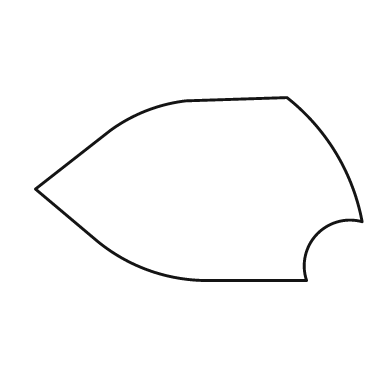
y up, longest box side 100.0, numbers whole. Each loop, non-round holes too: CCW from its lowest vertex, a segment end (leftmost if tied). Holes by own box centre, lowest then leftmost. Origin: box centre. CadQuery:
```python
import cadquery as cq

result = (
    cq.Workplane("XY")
    .moveTo(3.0, -28.0)
    .lineTo(33.0, -28.0)
    .threePointArc((36.0, -14.0), (50.0, -10.0))
    .threePointArc((42.0, 11.0), (27.0, 28.0))
    .lineTo(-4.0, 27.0)
    .threePointArc((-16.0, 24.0), (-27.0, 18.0))
    .lineTo(-50.0, 0.0)
    .lineTo(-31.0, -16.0)
    .threePointArc((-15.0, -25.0), (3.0, -28.0))
    .close()
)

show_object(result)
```